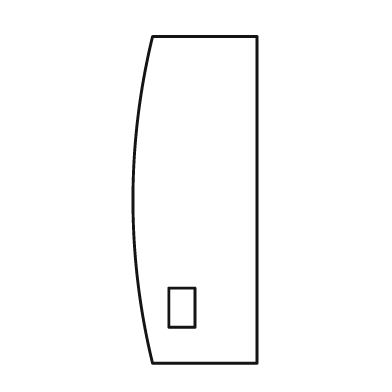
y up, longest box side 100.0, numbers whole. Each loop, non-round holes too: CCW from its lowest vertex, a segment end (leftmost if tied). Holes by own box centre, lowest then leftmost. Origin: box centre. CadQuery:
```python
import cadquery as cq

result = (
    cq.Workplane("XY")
    .moveTo(-13.0, -50.0)
    .lineTo(19.0, -50.0)
    .lineTo(19.0, 50.0)
    .lineTo(-13.0, 50.0)
    .threePointArc((-19.0, 0.0), (-13.0, -50.0))
    .close()
    .moveTo(-8.0, -39.0)
    .lineTo(0.0, -39.0)
    .lineTo(0.0, -27.0)
    .lineTo(-8.0, -27.0)
    .close()
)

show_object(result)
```